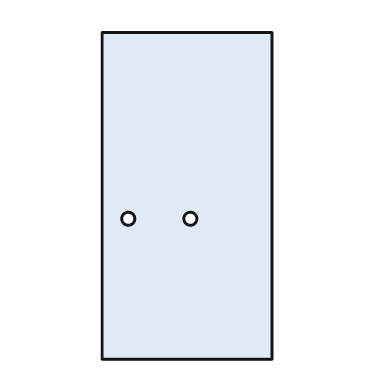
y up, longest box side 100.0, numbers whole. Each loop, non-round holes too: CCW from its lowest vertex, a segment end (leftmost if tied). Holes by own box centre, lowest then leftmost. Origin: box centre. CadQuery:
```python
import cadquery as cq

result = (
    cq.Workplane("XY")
    .moveTo(-26.0, -50.0)
    .lineTo(26.0, -50.0)
    .lineTo(26.0, 50.0)
    .lineTo(-26.0, 50.0)
    .close()
    .moveTo(-18.0, -7.0)
    .circle(2.0)
    .moveTo(1.0, -7.0)
    .circle(2.0)
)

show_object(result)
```